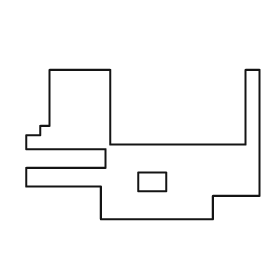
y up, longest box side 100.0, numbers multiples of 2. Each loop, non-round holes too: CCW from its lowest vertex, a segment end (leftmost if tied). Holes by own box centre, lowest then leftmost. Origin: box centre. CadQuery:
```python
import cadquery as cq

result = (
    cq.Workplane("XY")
    .moveTo(-18.0, -32.0)
    .lineTo(30.0, -32.0)
    .lineTo(30.0, -22.0)
    .lineTo(50.0, -22.0)
    .lineTo(50.0, 32.0)
    .lineTo(44.0, 32.0)
    .lineTo(44.0, 0.0)
    .lineTo(-14.0, 0.0)
    .lineTo(-14.0, 32.0)
    .lineTo(-40.0, 32.0)
    .lineTo(-40.0, 8.0)
    .lineTo(-44.0, 8.0)
    .lineTo(-44.0, 4.0)
    .lineTo(-50.0, 4.0)
    .lineTo(-50.0, -2.0)
    .lineTo(-16.0, -2.0)
    .lineTo(-16.0, -10.0)
    .lineTo(-50.0, -10.0)
    .lineTo(-50.0, -18.0)
    .lineTo(-18.0, -18.0)
    .close()
    .moveTo(-2.0, -20.0)
    .lineTo(10.0, -20.0)
    .lineTo(10.0, -12.0)
    .lineTo(-2.0, -12.0)
    .close()
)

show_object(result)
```